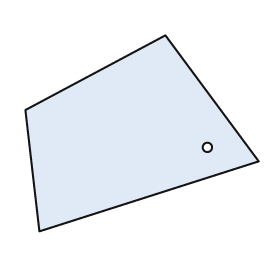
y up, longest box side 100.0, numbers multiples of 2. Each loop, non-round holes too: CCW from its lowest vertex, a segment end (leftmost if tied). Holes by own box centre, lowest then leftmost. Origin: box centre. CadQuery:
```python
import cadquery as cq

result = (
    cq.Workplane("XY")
    .moveTo(-44.0, -42.0)
    .lineTo(50.0, -12.0)
    .lineTo(10.0, 42.0)
    .lineTo(-50.0, 10.0)
    .close()
    .moveTo(28.0, -6.0)
    .circle(2.0)
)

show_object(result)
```